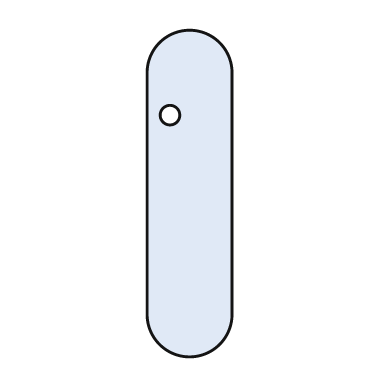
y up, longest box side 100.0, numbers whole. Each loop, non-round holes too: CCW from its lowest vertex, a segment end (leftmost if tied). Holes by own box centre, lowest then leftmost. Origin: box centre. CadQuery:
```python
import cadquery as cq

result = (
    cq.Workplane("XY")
    .moveTo(-13.0, -37.0)
    .threePointArc((0.0, -50.0), (13.0, -37.0))
    .lineTo(13.0, 37.0)
    .threePointArc((0.0, 50.0), (-13.0, 37.0))
    .close()
    .moveTo(-6.0, 24.0)
    .circle(3.0)
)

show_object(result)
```